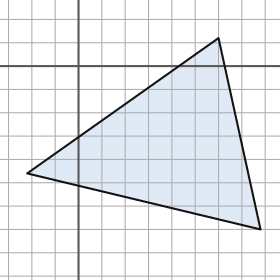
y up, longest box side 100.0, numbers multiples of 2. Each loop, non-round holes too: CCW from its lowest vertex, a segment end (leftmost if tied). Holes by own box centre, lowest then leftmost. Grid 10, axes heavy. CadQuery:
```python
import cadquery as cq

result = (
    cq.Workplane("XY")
    .moveTo(78.0, -70.0)
    .lineTo(60.0, 12.0)
    .lineTo(-22.0, -46.0)
    .close()
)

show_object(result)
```